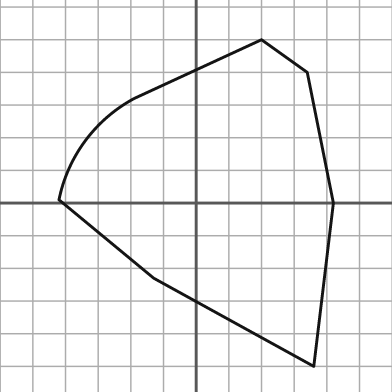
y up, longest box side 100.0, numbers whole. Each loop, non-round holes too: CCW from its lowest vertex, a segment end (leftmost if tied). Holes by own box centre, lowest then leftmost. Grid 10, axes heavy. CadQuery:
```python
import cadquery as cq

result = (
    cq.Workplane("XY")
    .moveTo(36.0, -50.0)
    .lineTo(42.0, 0.0)
    .lineTo(34.0, 40.0)
    .lineTo(20.0, 50.0)
    .lineTo(-19.0, 32.0)
    .threePointArc((-34.0, 19.0), (-42.0, 1.0))
    .lineTo(-13.0, -23.0)
    .close()
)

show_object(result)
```